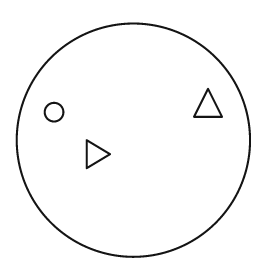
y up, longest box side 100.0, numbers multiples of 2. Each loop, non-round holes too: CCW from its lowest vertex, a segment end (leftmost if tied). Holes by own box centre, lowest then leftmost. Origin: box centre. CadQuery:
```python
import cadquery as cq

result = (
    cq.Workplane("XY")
    .moveTo(0.0, 0.0)
    .circle(50.0)
    .moveTo(-20.0, -12.0)
    .lineTo(-10.0, -6.0)
    .lineTo(-20.0, 0.0)
    .close()
    .moveTo(-34.0, 12.0)
    .circle(4.0)
    .moveTo(26.0, 10.0)
    .lineTo(38.0, 10.0)
    .lineTo(32.0, 22.0)
    .close()
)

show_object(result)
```